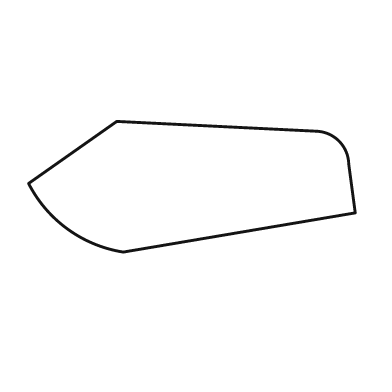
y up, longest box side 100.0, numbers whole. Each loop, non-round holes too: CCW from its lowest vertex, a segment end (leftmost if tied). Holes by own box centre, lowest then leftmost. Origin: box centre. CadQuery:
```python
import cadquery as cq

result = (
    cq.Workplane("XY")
    .moveTo(-21.0, -20.0)
    .lineTo(50.0, -8.0)
    .lineTo(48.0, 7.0)
    .threePointArc((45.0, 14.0), (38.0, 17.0))
    .lineTo(-23.0, 20.0)
    .lineTo(-50.0, 1.0)
    .threePointArc((-38.0, -13.0), (-21.0, -20.0))
    .close()
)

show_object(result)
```